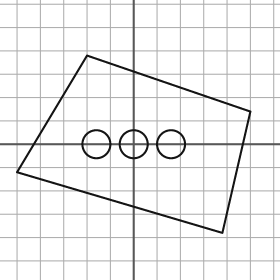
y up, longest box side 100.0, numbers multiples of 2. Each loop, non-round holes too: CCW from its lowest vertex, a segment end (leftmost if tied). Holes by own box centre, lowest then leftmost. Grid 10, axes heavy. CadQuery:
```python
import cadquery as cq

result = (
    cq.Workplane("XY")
    .moveTo(38.0, -38.0)
    .lineTo(50.0, 14.0)
    .lineTo(-20.0, 38.0)
    .lineTo(-50.0, -12.0)
    .close()
    .moveTo(-16.0, 0.0)
    .circle(6.0)
    .moveTo(0.0, 0.0)
    .circle(6.0)
    .moveTo(16.0, 0.0)
    .circle(6.0)
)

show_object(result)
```